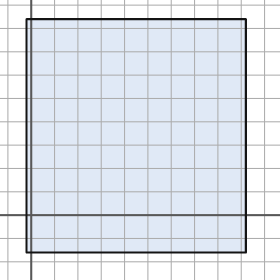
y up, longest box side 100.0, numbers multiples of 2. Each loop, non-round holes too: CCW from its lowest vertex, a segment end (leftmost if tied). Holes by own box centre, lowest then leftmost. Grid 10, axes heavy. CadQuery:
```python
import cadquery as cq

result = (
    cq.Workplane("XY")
    .moveTo(-2.0, -16.0)
    .lineTo(92.0, -16.0)
    .lineTo(92.0, 84.0)
    .lineTo(-2.0, 84.0)
    .close()
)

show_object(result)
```